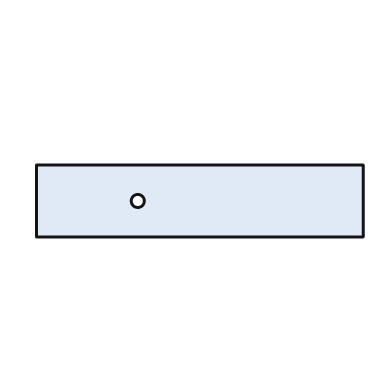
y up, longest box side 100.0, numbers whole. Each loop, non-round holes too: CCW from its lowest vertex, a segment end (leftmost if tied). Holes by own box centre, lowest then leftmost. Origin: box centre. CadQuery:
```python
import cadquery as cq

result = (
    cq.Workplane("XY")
    .moveTo(-50.0, -11.0)
    .lineTo(50.0, -11.0)
    .lineTo(50.0, 11.0)
    .lineTo(-50.0, 11.0)
    .close()
    .moveTo(-19.0, 0.0)
    .circle(2.0)
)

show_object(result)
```